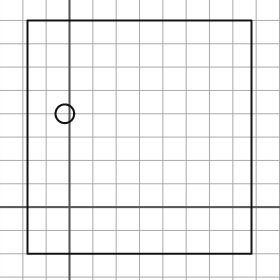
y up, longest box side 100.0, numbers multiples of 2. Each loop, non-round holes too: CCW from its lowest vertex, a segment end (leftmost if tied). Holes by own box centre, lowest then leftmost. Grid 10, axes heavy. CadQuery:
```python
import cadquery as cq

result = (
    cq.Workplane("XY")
    .moveTo(-18.0, -20.0)
    .lineTo(78.0, -20.0)
    .lineTo(78.0, 80.0)
    .lineTo(-18.0, 80.0)
    .close()
    .moveTo(-2.0, 40.0)
    .circle(4.0)
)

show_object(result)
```